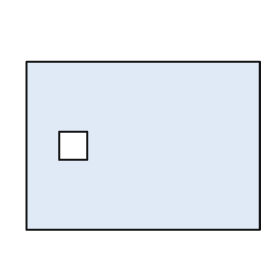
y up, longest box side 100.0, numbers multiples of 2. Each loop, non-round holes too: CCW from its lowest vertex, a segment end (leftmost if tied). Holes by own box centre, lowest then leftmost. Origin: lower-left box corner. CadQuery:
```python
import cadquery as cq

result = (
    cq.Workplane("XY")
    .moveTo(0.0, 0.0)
    .lineTo(100.0, 0.0)
    .lineTo(100.0, 72.0)
    .lineTo(0.0, 72.0)
    .close()
    .moveTo(14.0, 30.0)
    .lineTo(26.0, 30.0)
    .lineTo(26.0, 42.0)
    .lineTo(14.0, 42.0)
    .close()
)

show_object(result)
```